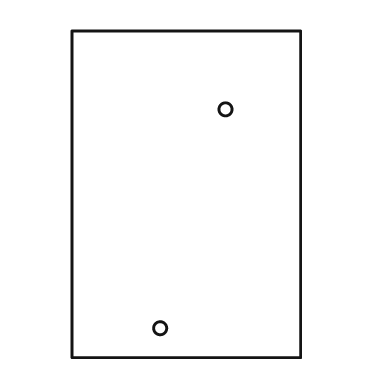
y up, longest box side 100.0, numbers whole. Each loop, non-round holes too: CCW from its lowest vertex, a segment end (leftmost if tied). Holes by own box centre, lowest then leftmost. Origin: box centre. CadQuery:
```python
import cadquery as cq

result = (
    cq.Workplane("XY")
    .moveTo(-35.0, -50.0)
    .lineTo(35.0, -50.0)
    .lineTo(35.0, 50.0)
    .lineTo(-35.0, 50.0)
    .close()
    .moveTo(-8.0, -41.0)
    .circle(2.0)
    .moveTo(12.0, 26.0)
    .circle(2.0)
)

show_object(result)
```